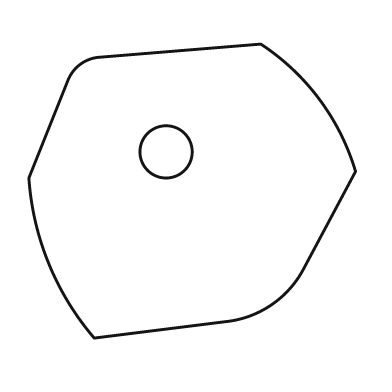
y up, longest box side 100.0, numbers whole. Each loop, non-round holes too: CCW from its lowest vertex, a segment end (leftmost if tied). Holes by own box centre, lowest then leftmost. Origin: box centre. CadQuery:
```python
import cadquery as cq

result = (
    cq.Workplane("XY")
    .moveTo(-30.0, -45.0)
    .lineTo(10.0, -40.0)
    .threePointArc((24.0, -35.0), (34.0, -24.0))
    .lineTo(50.0, 6.0)
    .threePointArc((39.0, 28.0), (21.0, 45.0))
    .lineTo(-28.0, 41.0)
    .threePointArc((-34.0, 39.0), (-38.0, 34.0))
    .lineTo(-50.0, 4.0)
    .threePointArc((-44.0, -22.0), (-30.0, -45.0))
    .close()
    .moveTo(-8.0, 12.0)
    .circle(8.0)
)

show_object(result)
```